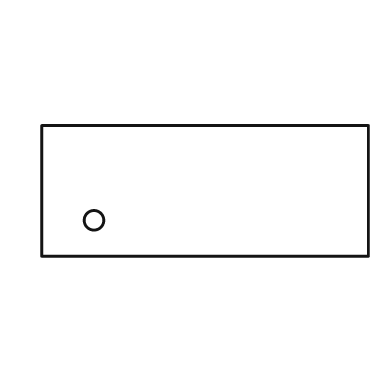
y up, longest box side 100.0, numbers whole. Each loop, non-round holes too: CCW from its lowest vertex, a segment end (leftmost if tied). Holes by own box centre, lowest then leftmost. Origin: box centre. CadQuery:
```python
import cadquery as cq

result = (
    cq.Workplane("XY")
    .moveTo(-50.0, -20.0)
    .lineTo(50.0, -20.0)
    .lineTo(50.0, 20.0)
    .lineTo(-50.0, 20.0)
    .close()
    .moveTo(-34.0, -9.0)
    .circle(3.0)
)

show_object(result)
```